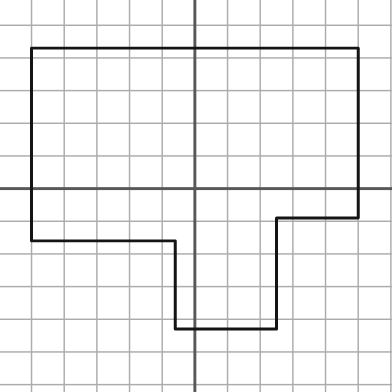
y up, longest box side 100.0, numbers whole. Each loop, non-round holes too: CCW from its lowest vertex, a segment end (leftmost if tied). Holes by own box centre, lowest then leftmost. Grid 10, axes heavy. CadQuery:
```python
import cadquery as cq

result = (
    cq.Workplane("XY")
    .moveTo(-6.0, -43.0)
    .lineTo(25.0, -43.0)
    .lineTo(25.0, -9.0)
    .lineTo(50.0, -9.0)
    .lineTo(50.0, 43.0)
    .lineTo(-50.0, 43.0)
    .lineTo(-50.0, -16.0)
    .lineTo(-6.0, -16.0)
    .close()
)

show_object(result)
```